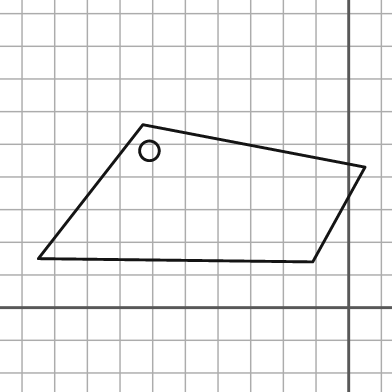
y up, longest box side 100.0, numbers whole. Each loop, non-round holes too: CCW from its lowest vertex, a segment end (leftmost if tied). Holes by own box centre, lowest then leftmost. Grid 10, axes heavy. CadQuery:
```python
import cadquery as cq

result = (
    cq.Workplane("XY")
    .moveTo(-11.0, 14.0)
    .lineTo(5.0, 43.0)
    .lineTo(-63.0, 56.0)
    .lineTo(-95.0, 15.0)
    .close()
    .moveTo(-61.0, 48.0)
    .circle(3.0)
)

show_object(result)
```